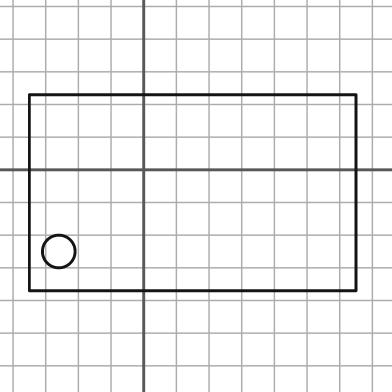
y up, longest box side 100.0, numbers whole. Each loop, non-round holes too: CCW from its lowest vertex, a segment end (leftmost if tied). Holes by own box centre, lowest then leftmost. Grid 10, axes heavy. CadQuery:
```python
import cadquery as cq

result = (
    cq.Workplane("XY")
    .moveTo(-35.0, -37.0)
    .lineTo(65.0, -37.0)
    .lineTo(65.0, 23.0)
    .lineTo(-35.0, 23.0)
    .close()
    .moveTo(-26.0, -25.0)
    .circle(5.0)
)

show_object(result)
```